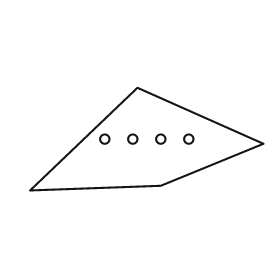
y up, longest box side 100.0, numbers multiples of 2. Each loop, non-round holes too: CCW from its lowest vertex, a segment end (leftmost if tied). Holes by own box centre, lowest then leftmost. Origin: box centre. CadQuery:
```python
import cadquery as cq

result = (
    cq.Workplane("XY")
    .moveTo(-50.0, -22.0)
    .lineTo(6.0, -20.0)
    .lineTo(50.0, -2.0)
    .lineTo(-4.0, 22.0)
    .close()
    .moveTo(-18.0, 0.0)
    .circle(2.0)
    .moveTo(-6.0, 0.0)
    .circle(2.0)
    .moveTo(6.0, 0.0)
    .circle(2.0)
    .moveTo(18.0, 0.0)
    .circle(2.0)
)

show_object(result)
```